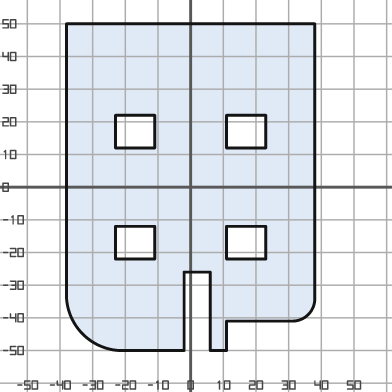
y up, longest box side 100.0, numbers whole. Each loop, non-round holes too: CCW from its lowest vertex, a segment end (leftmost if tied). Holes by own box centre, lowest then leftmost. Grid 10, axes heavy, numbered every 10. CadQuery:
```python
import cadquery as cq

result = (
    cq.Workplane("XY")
    .moveTo(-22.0, -50.0)
    .lineTo(-2.0, -50.0)
    .lineTo(-2.0, -26.0)
    .lineTo(6.0, -26.0)
    .lineTo(6.0, -50.0)
    .lineTo(11.0, -50.0)
    .lineTo(11.0, -41.0)
    .lineTo(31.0, -41.0)
    .threePointArc((36.0, -39.0), (38.0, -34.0))
    .lineTo(38.0, 50.0)
    .lineTo(-38.0, 50.0)
    .lineTo(-38.0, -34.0)
    .threePointArc((-33.0, -45.0), (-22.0, -50.0))
    .close()
    .moveTo(-23.0, -22.0)
    .lineTo(-11.0, -22.0)
    .lineTo(-11.0, -12.0)
    .lineTo(-23.0, -12.0)
    .close()
    .moveTo(11.0, -22.0)
    .lineTo(23.0, -22.0)
    .lineTo(23.0, -12.0)
    .lineTo(11.0, -12.0)
    .close()
    .moveTo(-23.0, 12.0)
    .lineTo(-11.0, 12.0)
    .lineTo(-11.0, 22.0)
    .lineTo(-23.0, 22.0)
    .close()
    .moveTo(11.0, 12.0)
    .lineTo(23.0, 12.0)
    .lineTo(23.0, 22.0)
    .lineTo(11.0, 22.0)
    .close()
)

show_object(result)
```